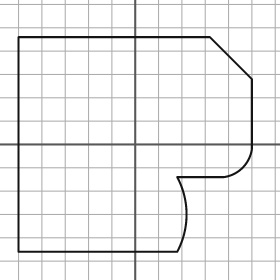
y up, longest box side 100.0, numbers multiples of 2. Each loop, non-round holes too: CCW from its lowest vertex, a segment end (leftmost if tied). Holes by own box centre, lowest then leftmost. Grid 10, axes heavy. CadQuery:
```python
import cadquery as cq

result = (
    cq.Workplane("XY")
    .moveTo(-50.0, -46.0)
    .lineTo(18.0, -46.0)
    .threePointArc((22.0, -30.0), (18.0, -14.0))
    .lineTo(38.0, -14.0)
    .threePointArc((46.0, -10.0), (50.0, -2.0))
    .lineTo(50.0, 28.0)
    .lineTo(32.0, 46.0)
    .lineTo(-50.0, 46.0)
    .close()
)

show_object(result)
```